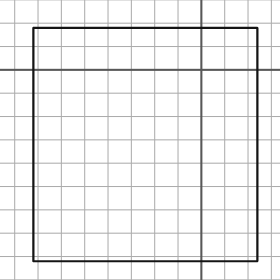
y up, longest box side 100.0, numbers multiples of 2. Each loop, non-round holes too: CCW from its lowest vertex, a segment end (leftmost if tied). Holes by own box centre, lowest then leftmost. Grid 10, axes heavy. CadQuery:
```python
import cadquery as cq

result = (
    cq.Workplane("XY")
    .moveTo(-72.0, -82.0)
    .lineTo(24.0, -82.0)
    .lineTo(24.0, 18.0)
    .lineTo(-72.0, 18.0)
    .close()
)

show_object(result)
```